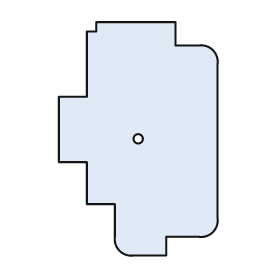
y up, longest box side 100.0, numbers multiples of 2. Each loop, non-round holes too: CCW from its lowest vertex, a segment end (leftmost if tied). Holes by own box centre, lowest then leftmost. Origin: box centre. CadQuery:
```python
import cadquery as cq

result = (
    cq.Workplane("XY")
    .moveTo(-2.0, -50.0)
    .lineTo(12.0, -50.0)
    .lineTo(12.0, -42.0)
    .lineTo(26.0, -42.0)
    .threePointArc((32.0, -40.0), (34.0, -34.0))
    .lineTo(34.0, 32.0)
    .threePointArc((32.0, 38.0), (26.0, 40.0))
    .lineTo(16.0, 40.0)
    .lineTo(16.0, 50.0)
    .lineTo(-18.0, 50.0)
    .lineTo(-18.0, 46.0)
    .lineTo(-22.0, 46.0)
    .lineTo(-22.0, 18.0)
    .lineTo(-34.0, 18.0)
    .lineTo(-34.0, -10.0)
    .lineTo(-22.0, -10.0)
    .lineTo(-22.0, -28.0)
    .lineTo(-10.0, -28.0)
    .lineTo(-10.0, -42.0)
    .threePointArc((-8.0, -48.0), (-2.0, -50.0))
    .close()
    .moveTo(0.0, 0.0)
    .circle(2.0)
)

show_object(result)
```